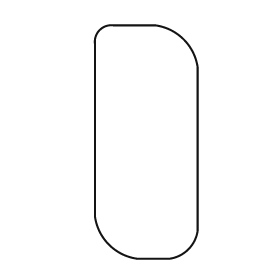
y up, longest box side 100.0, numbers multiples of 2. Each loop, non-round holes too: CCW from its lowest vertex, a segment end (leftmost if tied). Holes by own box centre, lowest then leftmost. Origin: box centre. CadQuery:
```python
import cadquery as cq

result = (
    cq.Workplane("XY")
    .moveTo(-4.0, -50.0)
    .lineTo(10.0, -50.0)
    .threePointArc((18.0, -46.0), (22.0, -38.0))
    .lineTo(22.0, 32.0)
    .threePointArc((16.0, 44.0), (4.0, 50.0))
    .lineTo(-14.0, 50.0)
    .threePointArc((-20.0, 48.0), (-22.0, 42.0))
    .lineTo(-22.0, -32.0)
    .threePointArc((-16.0, -44.0), (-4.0, -50.0))
    .close()
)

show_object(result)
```